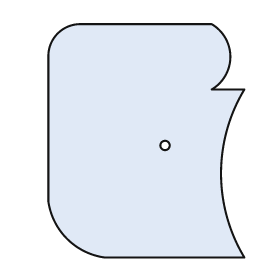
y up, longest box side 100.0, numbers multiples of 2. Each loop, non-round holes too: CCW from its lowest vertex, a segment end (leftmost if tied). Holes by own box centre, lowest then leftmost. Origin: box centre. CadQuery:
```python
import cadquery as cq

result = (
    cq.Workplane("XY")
    .moveTo(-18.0, -50.0)
    .lineTo(42.0, -50.0)
    .threePointArc((32.0, -14.0), (42.0, 22.0))
    .lineTo(28.0, 22.0)
    .threePointArc((36.0, 36.0), (28.0, 50.0))
    .lineTo(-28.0, 50.0)
    .threePointArc((-38.0, 46.0), (-42.0, 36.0))
    .lineTo(-42.0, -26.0)
    .threePointArc((-34.0, -42.0), (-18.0, -50.0))
    .close()
    .moveTo(8.0, -2.0)
    .circle(2.0)
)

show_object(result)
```